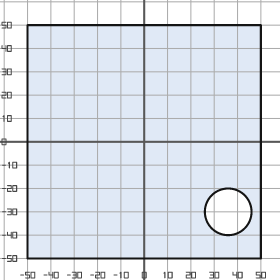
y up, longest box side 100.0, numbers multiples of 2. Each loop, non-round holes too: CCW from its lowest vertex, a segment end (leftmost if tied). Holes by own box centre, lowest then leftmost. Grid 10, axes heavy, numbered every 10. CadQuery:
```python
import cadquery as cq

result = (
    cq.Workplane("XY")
    .moveTo(-50.0, -50.0)
    .lineTo(50.0, -50.0)
    .lineTo(50.0, 50.0)
    .lineTo(-50.0, 50.0)
    .close()
    .moveTo(36.0, -30.0)
    .circle(10.0)
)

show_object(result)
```